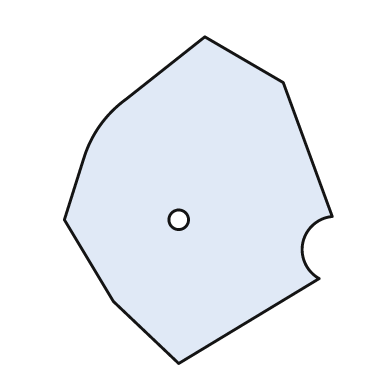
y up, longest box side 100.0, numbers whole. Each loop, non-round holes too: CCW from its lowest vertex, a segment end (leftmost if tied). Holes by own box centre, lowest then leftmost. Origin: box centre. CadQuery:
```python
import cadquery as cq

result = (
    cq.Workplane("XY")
    .moveTo(-6.0, -50.0)
    .lineTo(37.0, -24.0)
    .threePointArc((32.0, -13.0), (41.0, -5.0))
    .lineTo(26.0, 36.0)
    .lineTo(2.0, 50.0)
    .lineTo(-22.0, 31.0)
    .threePointArc((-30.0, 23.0), (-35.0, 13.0))
    .lineTo(-41.0, -6.0)
    .lineTo(-26.0, -31.0)
    .close()
    .moveTo(-6.0, -6.0)
    .circle(3.0)
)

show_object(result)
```